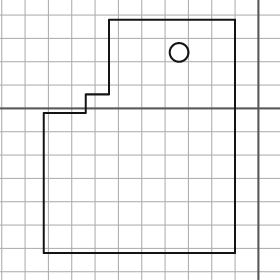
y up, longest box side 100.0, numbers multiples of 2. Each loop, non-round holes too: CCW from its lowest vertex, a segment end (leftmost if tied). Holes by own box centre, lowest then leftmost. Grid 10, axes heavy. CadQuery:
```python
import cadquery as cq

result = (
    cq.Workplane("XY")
    .moveTo(-92.0, -62.0)
    .lineTo(-10.0, -62.0)
    .lineTo(-10.0, 38.0)
    .lineTo(-64.0, 38.0)
    .lineTo(-64.0, 6.0)
    .lineTo(-74.0, 6.0)
    .lineTo(-74.0, -2.0)
    .lineTo(-92.0, -2.0)
    .close()
    .moveTo(-34.0, 24.0)
    .circle(4.0)
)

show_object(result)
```